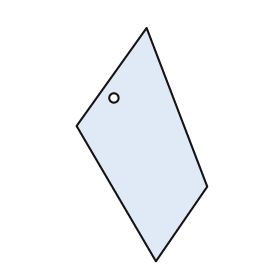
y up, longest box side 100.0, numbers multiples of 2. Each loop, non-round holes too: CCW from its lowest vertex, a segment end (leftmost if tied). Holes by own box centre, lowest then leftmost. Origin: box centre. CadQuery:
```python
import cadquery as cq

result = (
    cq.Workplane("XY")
    .moveTo(6.0, -50.0)
    .lineTo(28.0, -18.0)
    .lineTo(2.0, 50.0)
    .lineTo(-28.0, 8.0)
    .close()
    .moveTo(-12.0, 20.0)
    .circle(2.0)
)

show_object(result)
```